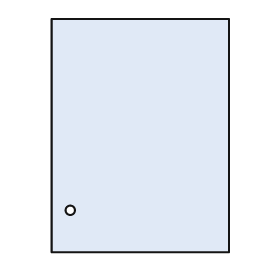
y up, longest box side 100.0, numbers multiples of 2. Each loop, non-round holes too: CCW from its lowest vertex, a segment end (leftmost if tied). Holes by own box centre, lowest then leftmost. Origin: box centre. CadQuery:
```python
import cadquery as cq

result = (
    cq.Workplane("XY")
    .moveTo(-38.0, -50.0)
    .lineTo(38.0, -50.0)
    .lineTo(38.0, 50.0)
    .lineTo(-38.0, 50.0)
    .close()
    .moveTo(-30.0, -32.0)
    .circle(2.0)
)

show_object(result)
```